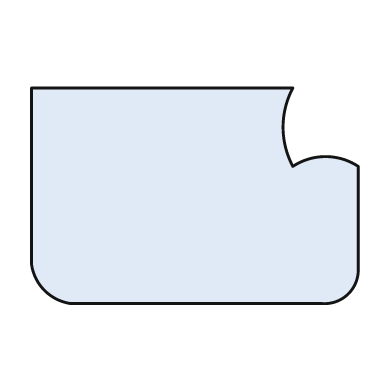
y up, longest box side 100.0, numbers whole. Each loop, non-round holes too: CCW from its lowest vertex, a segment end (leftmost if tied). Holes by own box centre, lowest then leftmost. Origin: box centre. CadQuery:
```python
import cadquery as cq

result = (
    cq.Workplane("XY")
    .moveTo(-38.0, -33.0)
    .lineTo(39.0, -33.0)
    .threePointArc((47.0, -30.0), (50.0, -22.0))
    .lineTo(50.0, 9.0)
    .threePointArc((40.0, 12.0), (30.0, 9.0))
    .threePointArc((27.0, 21.0), (30.0, 33.0))
    .lineTo(-50.0, 33.0)
    .lineTo(-50.0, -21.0)
    .threePointArc((-46.0, -29.0), (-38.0, -33.0))
    .close()
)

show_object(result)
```